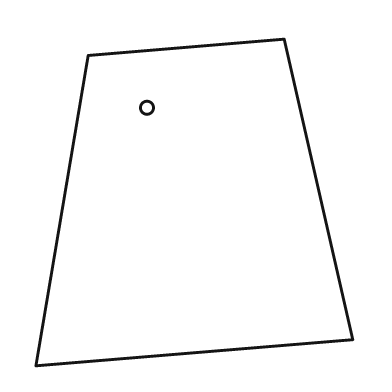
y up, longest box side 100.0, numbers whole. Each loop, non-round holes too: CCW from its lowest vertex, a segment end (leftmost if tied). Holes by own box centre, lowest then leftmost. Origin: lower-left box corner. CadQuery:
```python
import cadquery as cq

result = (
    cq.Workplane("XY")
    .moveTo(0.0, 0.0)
    .lineTo(97.0, 8.0)
    .lineTo(76.0, 100.0)
    .lineTo(16.0, 95.0)
    .close()
    .moveTo(34.0, 79.0)
    .circle(2.0)
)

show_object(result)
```